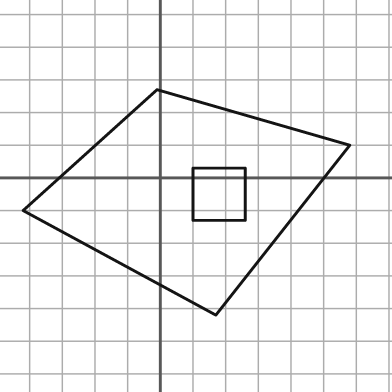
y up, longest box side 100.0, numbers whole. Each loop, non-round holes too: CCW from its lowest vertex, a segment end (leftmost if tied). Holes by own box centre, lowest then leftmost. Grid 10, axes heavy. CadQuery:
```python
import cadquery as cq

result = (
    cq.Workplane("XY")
    .moveTo(17.0, -42.0)
    .lineTo(58.0, 10.0)
    .lineTo(-1.0, 27.0)
    .lineTo(-42.0, -10.0)
    .close()
    .moveTo(10.0, -13.0)
    .lineTo(26.0, -13.0)
    .lineTo(26.0, 3.0)
    .lineTo(10.0, 3.0)
    .close()
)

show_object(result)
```